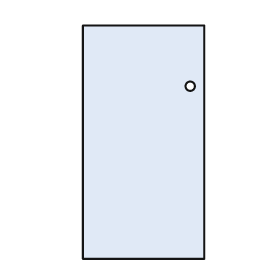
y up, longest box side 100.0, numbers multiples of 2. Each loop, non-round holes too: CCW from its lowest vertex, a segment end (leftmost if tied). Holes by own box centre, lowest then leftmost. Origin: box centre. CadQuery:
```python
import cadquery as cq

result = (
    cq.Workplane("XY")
    .moveTo(-26.0, -50.0)
    .lineTo(26.0, -50.0)
    .lineTo(26.0, 50.0)
    .lineTo(-26.0, 50.0)
    .close()
    .moveTo(20.0, 24.0)
    .circle(2.0)
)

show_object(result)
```